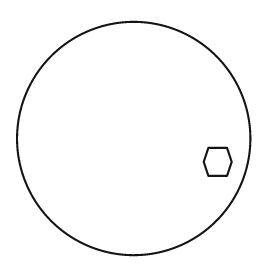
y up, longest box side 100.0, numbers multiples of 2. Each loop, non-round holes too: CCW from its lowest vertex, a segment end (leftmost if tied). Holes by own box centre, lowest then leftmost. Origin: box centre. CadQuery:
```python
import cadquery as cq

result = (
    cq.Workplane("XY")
    .moveTo(0.0, 0.0)
    .circle(50.0)
    .moveTo(32.0, -16.0)
    .lineTo(40.0, -16.0)
    .lineTo(42.0, -10.0)
    .lineTo(40.0, -4.0)
    .lineTo(32.0, -4.0)
    .lineTo(30.0, -10.0)
    .close()
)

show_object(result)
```